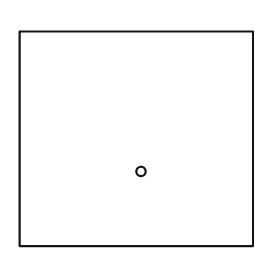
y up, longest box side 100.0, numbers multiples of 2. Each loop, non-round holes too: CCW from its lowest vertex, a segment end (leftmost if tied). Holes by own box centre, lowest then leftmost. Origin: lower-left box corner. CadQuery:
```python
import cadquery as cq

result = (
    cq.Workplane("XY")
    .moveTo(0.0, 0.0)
    .lineTo(100.0, 0.0)
    .lineTo(100.0, 92.0)
    .lineTo(0.0, 92.0)
    .close()
    .moveTo(52.0, 32.0)
    .circle(2.0)
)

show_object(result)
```